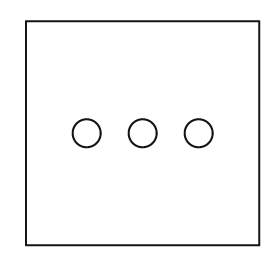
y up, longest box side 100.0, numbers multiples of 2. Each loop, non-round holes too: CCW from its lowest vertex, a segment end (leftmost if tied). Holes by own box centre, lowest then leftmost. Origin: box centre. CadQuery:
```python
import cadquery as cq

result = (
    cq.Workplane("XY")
    .moveTo(-50.0, -48.0)
    .lineTo(50.0, -48.0)
    .lineTo(50.0, 48.0)
    .lineTo(-50.0, 48.0)
    .close()
    .moveTo(-24.0, 0.0)
    .circle(6.0)
    .moveTo(0.0, 0.0)
    .circle(6.0)
    .moveTo(24.0, 0.0)
    .circle(6.0)
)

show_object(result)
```